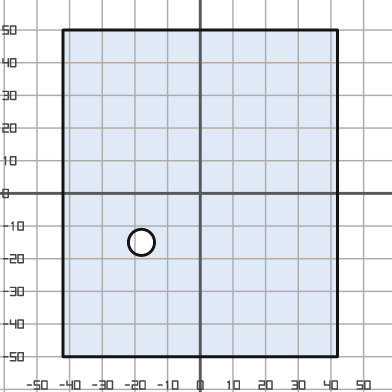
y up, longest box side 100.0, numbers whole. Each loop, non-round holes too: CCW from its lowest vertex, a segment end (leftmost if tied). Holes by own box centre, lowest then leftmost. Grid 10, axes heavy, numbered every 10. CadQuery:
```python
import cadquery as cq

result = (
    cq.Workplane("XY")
    .moveTo(-42.0, -50.0)
    .lineTo(42.0, -50.0)
    .lineTo(42.0, 50.0)
    .lineTo(-42.0, 50.0)
    .close()
    .moveTo(-18.0, -15.0)
    .circle(4.0)
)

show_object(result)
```